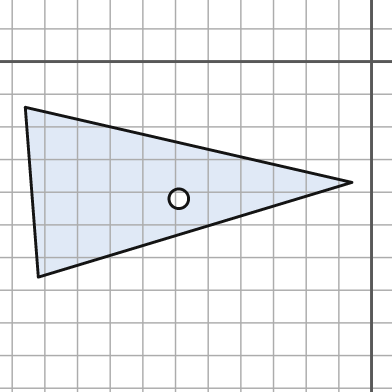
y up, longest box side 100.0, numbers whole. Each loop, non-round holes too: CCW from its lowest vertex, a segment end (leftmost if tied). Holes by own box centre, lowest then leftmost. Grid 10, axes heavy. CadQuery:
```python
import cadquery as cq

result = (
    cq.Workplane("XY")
    .moveTo(-102.0, -66.0)
    .lineTo(-6.0, -37.0)
    .lineTo(-106.0, -14.0)
    .close()
    .moveTo(-59.0, -42.0)
    .circle(3.0)
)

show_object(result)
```